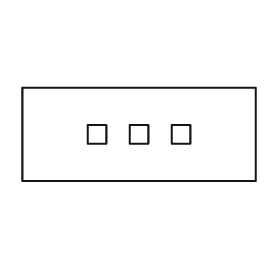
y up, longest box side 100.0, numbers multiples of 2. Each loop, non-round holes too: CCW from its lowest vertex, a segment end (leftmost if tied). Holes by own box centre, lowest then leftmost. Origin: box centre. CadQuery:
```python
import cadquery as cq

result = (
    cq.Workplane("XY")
    .moveTo(-50.0, -20.0)
    .lineTo(50.0, -20.0)
    .lineTo(50.0, 20.0)
    .lineTo(-50.0, 20.0)
    .close()
    .moveTo(-22.0, -4.0)
    .lineTo(-14.0, -4.0)
    .lineTo(-14.0, 4.0)
    .lineTo(-22.0, 4.0)
    .close()
    .moveTo(-4.0, -4.0)
    .lineTo(4.0, -4.0)
    .lineTo(4.0, 4.0)
    .lineTo(-4.0, 4.0)
    .close()
    .moveTo(14.0, -4.0)
    .lineTo(22.0, -4.0)
    .lineTo(22.0, 4.0)
    .lineTo(14.0, 4.0)
    .close()
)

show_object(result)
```